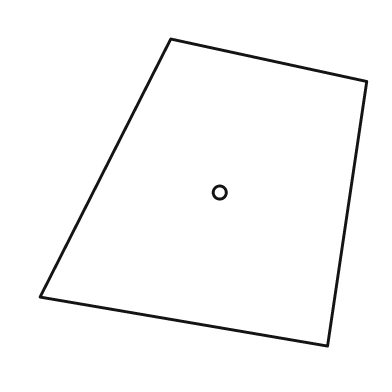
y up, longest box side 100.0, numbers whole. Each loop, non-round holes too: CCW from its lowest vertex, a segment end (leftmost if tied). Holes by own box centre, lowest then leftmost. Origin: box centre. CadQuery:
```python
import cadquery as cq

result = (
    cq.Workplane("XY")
    .moveTo(38.0, -47.0)
    .lineTo(50.0, 34.0)
    .lineTo(-10.0, 47.0)
    .lineTo(-50.0, -32.0)
    .close()
    .moveTo(5.0, 0.0)
    .circle(2.0)
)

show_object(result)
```